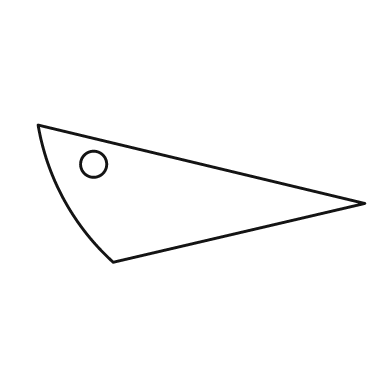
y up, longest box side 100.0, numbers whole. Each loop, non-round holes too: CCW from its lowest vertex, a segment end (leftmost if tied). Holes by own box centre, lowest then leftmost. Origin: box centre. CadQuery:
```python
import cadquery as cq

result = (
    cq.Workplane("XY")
    .moveTo(-27.0, -21.0)
    .lineTo(50.0, -3.0)
    .lineTo(-50.0, 21.0)
    .threePointArc((-42.0, -2.0), (-27.0, -21.0))
    .close()
    .moveTo(-33.0, 9.0)
    .circle(4.0)
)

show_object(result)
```